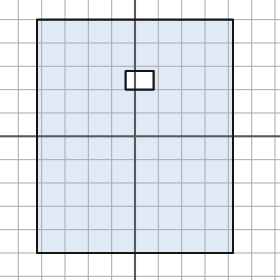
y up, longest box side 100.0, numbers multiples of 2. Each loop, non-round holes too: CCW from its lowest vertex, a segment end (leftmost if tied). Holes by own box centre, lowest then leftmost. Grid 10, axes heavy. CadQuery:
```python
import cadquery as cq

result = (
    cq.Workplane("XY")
    .moveTo(-42.0, -50.0)
    .lineTo(42.0, -50.0)
    .lineTo(42.0, 50.0)
    .lineTo(-42.0, 50.0)
    .close()
    .moveTo(-4.0, 20.0)
    .lineTo(8.0, 20.0)
    .lineTo(8.0, 28.0)
    .lineTo(-4.0, 28.0)
    .close()
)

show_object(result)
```